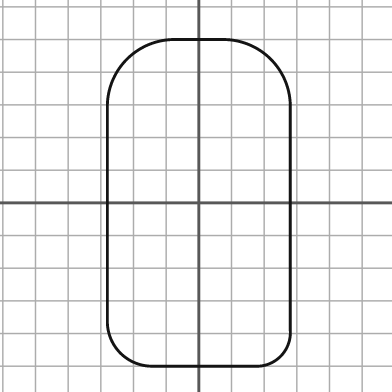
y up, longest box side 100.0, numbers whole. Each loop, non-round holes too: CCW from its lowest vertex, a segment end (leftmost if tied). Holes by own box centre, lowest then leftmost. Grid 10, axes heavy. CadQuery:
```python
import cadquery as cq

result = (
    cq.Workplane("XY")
    .moveTo(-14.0, -50.0)
    .lineTo(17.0, -50.0)
    .threePointArc((25.0, -47.0), (28.0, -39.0))
    .lineTo(28.0, 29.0)
    .threePointArc((22.0, 44.0), (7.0, 50.0))
    .lineTo(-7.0, 50.0)
    .threePointArc((-22.0, 44.0), (-28.0, 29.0))
    .lineTo(-28.0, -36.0)
    .threePointArc((-24.0, -46.0), (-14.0, -50.0))
    .close()
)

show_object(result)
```